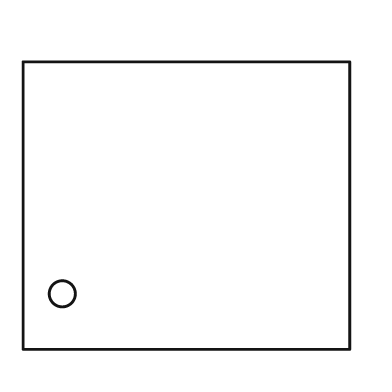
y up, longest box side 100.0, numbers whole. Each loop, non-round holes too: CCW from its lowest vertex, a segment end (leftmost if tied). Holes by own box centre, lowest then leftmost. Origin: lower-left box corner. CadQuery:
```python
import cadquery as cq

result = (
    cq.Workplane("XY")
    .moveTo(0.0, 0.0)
    .lineTo(100.0, 0.0)
    .lineTo(100.0, 88.0)
    .lineTo(0.0, 88.0)
    .close()
    .moveTo(12.0, 17.0)
    .circle(4.0)
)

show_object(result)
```